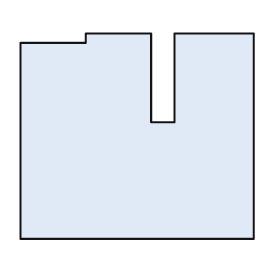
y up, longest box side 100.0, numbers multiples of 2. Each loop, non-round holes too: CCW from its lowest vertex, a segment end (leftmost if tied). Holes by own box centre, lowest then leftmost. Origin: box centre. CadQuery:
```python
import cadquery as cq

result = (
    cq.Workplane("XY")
    .moveTo(-50.0, -44.0)
    .lineTo(50.0, -44.0)
    .lineTo(50.0, 44.0)
    .lineTo(16.0, 44.0)
    .lineTo(16.0, 6.0)
    .lineTo(6.0, 6.0)
    .lineTo(6.0, 44.0)
    .lineTo(-22.0, 44.0)
    .lineTo(-22.0, 40.0)
    .lineTo(-50.0, 40.0)
    .close()
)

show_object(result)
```